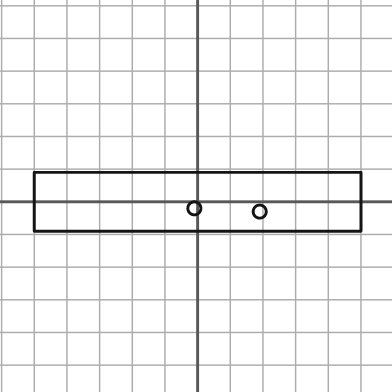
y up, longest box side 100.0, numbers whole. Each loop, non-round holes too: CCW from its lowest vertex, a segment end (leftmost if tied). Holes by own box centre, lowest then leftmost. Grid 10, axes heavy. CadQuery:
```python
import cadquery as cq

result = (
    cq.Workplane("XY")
    .moveTo(-50.0, -9.0)
    .lineTo(50.0, -9.0)
    .lineTo(50.0, 9.0)
    .lineTo(-50.0, 9.0)
    .close()
    .moveTo(19.0, -3.0)
    .circle(2.0)
    .moveTo(-1.0, -2.0)
    .circle(2.0)
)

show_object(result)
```